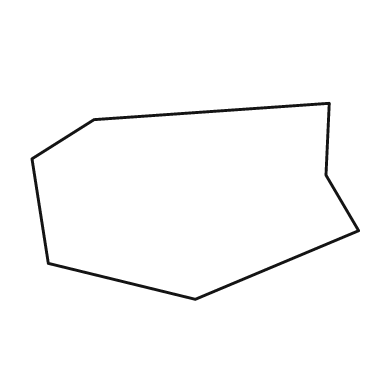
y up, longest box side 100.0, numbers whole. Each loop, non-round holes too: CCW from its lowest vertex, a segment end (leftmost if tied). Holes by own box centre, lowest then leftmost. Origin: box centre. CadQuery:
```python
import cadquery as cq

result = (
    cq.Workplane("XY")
    .moveTo(0.0, -30.0)
    .lineTo(50.0, -9.0)
    .lineTo(40.0, 8.0)
    .lineTo(41.0, 30.0)
    .lineTo(-31.0, 25.0)
    .lineTo(-50.0, 13.0)
    .lineTo(-45.0, -19.0)
    .close()
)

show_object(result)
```